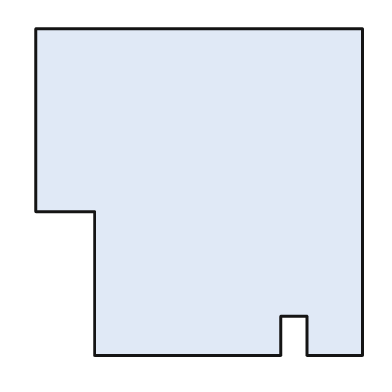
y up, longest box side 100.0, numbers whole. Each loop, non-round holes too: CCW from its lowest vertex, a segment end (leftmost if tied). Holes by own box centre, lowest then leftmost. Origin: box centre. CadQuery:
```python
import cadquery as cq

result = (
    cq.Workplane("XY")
    .moveTo(-32.0, -50.0)
    .lineTo(25.0, -50.0)
    .lineTo(25.0, -38.0)
    .lineTo(33.0, -38.0)
    .lineTo(33.0, -50.0)
    .lineTo(50.0, -50.0)
    .lineTo(50.0, 50.0)
    .lineTo(-50.0, 50.0)
    .lineTo(-50.0, -6.0)
    .lineTo(-32.0, -6.0)
    .close()
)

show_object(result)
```